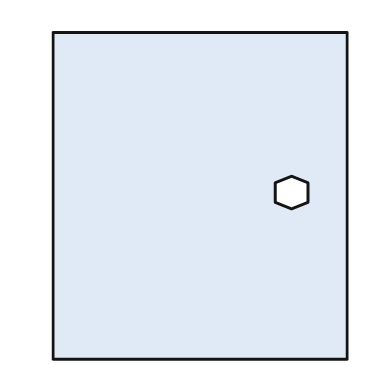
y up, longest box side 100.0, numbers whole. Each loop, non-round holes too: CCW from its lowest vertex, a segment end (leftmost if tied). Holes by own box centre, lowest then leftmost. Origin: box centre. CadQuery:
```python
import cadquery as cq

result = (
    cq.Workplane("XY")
    .moveTo(-45.0, -50.0)
    .lineTo(45.0, -50.0)
    .lineTo(45.0, 50.0)
    .lineTo(-45.0, 50.0)
    .close()
    .moveTo(28.0, -4.0)
    .lineTo(33.0, -2.0)
    .lineTo(33.0, 4.0)
    .lineTo(28.0, 6.0)
    .lineTo(23.0, 4.0)
    .lineTo(23.0, -2.0)
    .close()
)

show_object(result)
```